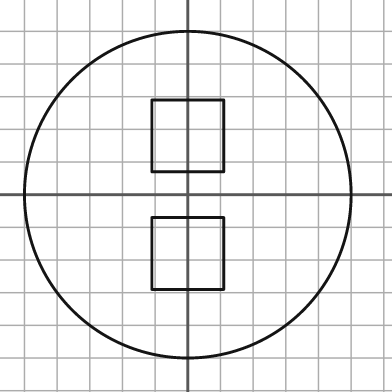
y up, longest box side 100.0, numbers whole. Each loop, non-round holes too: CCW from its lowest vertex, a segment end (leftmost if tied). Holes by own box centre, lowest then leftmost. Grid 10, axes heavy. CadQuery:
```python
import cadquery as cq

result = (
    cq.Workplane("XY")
    .moveTo(0.0, 0.0)
    .circle(50.0)
    .moveTo(-11.0, -29.0)
    .lineTo(11.0, -29.0)
    .lineTo(11.0, -7.0)
    .lineTo(-11.0, -7.0)
    .close()
    .moveTo(-11.0, 7.0)
    .lineTo(11.0, 7.0)
    .lineTo(11.0, 29.0)
    .lineTo(-11.0, 29.0)
    .close()
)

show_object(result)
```